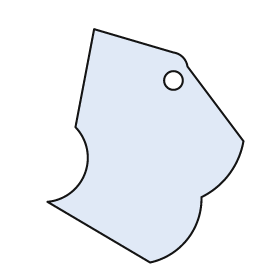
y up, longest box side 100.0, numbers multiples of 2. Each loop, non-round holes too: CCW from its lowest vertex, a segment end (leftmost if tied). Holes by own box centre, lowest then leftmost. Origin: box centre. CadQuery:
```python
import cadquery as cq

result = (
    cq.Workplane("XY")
    .moveTo(2.0, -50.0)
    .threePointArc((18.0, -40.0), (24.0, -22.0))
    .threePointArc((36.0, -12.0), (42.0, 2.0))
    .lineTo(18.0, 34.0)
    .threePointArc((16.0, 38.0), (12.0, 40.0))
    .lineTo(-22.0, 50.0)
    .lineTo(-30.0, 8.0)
    .threePointArc((-26.0, -12.0), (-42.0, -24.0))
    .close()
    .moveTo(12.0, 28.0)
    .circle(4.0)
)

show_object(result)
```